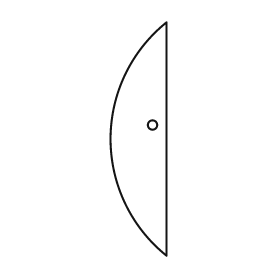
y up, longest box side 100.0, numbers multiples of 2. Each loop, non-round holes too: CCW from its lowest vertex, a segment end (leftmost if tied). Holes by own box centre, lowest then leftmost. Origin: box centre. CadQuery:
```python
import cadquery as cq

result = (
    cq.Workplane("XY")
    .moveTo(12.0, -50.0)
    .lineTo(12.0, 50.0)
    .threePointArc((-12.0, 0.0), (12.0, -50.0))
    .close()
    .moveTo(6.0, 6.0)
    .circle(2.0)
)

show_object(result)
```